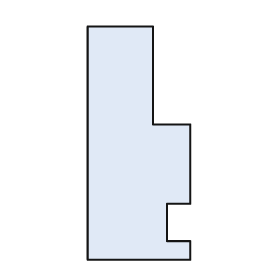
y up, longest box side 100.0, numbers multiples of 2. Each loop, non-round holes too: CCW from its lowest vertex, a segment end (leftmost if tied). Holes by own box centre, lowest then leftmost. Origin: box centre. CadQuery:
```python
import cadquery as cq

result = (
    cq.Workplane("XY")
    .moveTo(-22.0, -50.0)
    .lineTo(22.0, -50.0)
    .lineTo(22.0, -42.0)
    .lineTo(12.0, -42.0)
    .lineTo(12.0, -26.0)
    .lineTo(22.0, -26.0)
    .lineTo(22.0, 8.0)
    .lineTo(6.0, 8.0)
    .lineTo(6.0, 50.0)
    .lineTo(-22.0, 50.0)
    .close()
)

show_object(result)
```